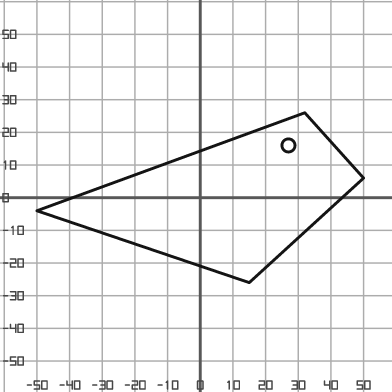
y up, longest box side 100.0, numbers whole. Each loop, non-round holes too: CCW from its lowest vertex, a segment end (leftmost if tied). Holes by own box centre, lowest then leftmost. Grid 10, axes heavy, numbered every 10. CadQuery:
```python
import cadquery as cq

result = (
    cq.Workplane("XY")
    .moveTo(15.0, -26.0)
    .lineTo(50.0, 6.0)
    .lineTo(32.0, 26.0)
    .lineTo(-50.0, -4.0)
    .close()
    .moveTo(27.0, 16.0)
    .circle(2.0)
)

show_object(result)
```